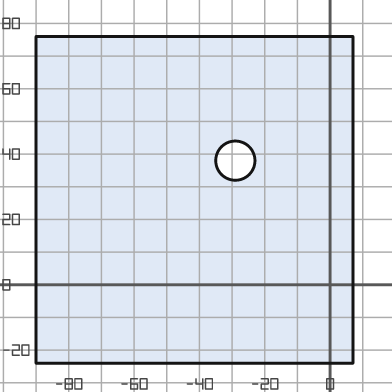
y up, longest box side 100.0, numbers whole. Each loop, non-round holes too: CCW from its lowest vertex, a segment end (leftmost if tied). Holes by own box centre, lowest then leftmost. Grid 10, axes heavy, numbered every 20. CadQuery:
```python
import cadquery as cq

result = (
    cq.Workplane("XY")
    .moveTo(-90.0, -24.0)
    .lineTo(7.0, -24.0)
    .lineTo(7.0, 76.0)
    .lineTo(-90.0, 76.0)
    .close()
    .moveTo(-29.0, 38.0)
    .circle(6.0)
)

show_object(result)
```